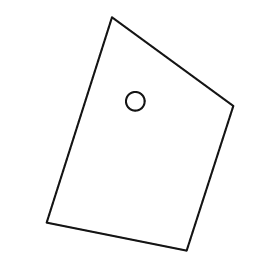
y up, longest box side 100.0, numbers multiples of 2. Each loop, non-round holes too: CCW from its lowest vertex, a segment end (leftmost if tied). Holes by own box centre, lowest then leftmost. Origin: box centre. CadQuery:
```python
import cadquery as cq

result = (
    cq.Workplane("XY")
    .moveTo(20.0, -50.0)
    .lineTo(40.0, 12.0)
    .lineTo(-12.0, 50.0)
    .lineTo(-40.0, -38.0)
    .close()
    .moveTo(-2.0, 14.0)
    .circle(4.0)
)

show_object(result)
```